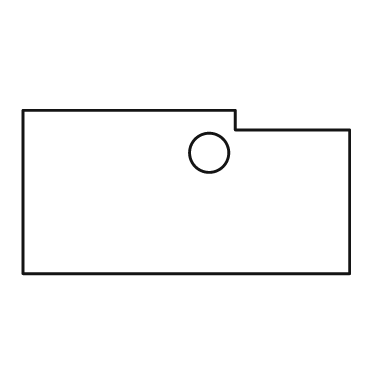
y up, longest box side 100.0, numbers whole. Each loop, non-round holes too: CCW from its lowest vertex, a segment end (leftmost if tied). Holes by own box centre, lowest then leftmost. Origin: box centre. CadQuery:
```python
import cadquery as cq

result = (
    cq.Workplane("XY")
    .moveTo(-50.0, -25.0)
    .lineTo(50.0, -25.0)
    .lineTo(50.0, 19.0)
    .lineTo(15.0, 19.0)
    .lineTo(15.0, 25.0)
    .lineTo(-50.0, 25.0)
    .close()
    .moveTo(7.0, 12.0)
    .circle(6.0)
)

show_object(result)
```